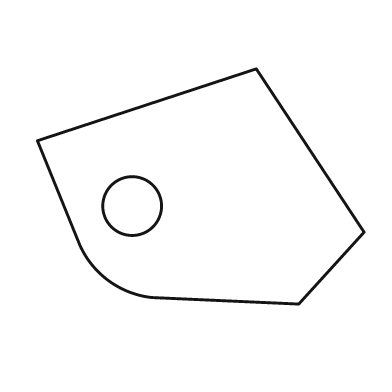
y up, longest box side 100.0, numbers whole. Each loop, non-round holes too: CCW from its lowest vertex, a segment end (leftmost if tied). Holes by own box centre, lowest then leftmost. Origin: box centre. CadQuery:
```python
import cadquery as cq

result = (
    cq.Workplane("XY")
    .moveTo(30.0, -36.0)
    .lineTo(50.0, -14.0)
    .lineTo(17.0, 36.0)
    .lineTo(-50.0, 14.0)
    .lineTo(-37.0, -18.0)
    .threePointArc((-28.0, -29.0), (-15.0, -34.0))
    .close()
    .moveTo(-21.0, -6.0)
    .circle(9.0)
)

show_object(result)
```